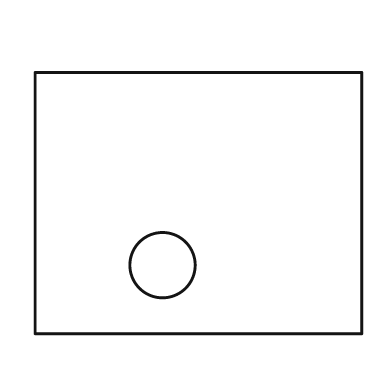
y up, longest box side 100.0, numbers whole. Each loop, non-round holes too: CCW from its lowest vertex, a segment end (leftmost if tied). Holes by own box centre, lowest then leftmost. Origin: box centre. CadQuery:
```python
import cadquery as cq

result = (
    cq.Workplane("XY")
    .moveTo(-50.0, -40.0)
    .lineTo(50.0, -40.0)
    .lineTo(50.0, 40.0)
    .lineTo(-50.0, 40.0)
    .close()
    .moveTo(-11.0, -19.0)
    .circle(10.0)
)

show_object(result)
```